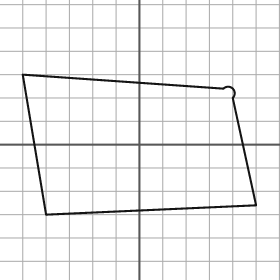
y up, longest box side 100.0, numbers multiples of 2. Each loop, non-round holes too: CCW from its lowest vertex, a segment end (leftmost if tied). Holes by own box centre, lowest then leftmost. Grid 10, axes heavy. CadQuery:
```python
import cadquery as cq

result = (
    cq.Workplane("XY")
    .moveTo(-40.0, -30.0)
    .lineTo(50.0, -26.0)
    .lineTo(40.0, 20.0)
    .threePointArc((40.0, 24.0), (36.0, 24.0))
    .lineTo(-50.0, 30.0)
    .close()
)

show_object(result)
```